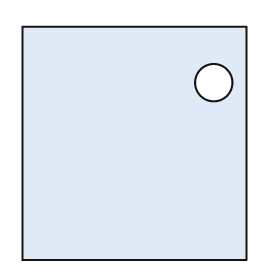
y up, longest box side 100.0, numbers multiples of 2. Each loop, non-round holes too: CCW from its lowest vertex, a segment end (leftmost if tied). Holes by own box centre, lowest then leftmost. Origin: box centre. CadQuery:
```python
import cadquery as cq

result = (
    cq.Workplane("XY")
    .moveTo(-48.0, -50.0)
    .lineTo(48.0, -50.0)
    .lineTo(48.0, 50.0)
    .lineTo(-48.0, 50.0)
    .close()
    .moveTo(34.0, 26.0)
    .circle(8.0)
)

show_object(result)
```